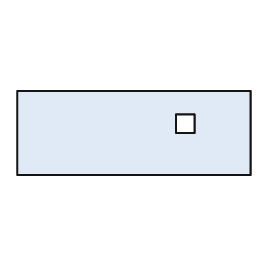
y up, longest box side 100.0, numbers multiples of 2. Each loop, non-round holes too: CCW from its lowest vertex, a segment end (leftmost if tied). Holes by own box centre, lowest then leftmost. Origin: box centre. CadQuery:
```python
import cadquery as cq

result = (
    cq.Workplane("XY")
    .moveTo(-50.0, -18.0)
    .lineTo(50.0, -18.0)
    .lineTo(50.0, 18.0)
    .lineTo(-50.0, 18.0)
    .close()
    .moveTo(18.0, 0.0)
    .lineTo(26.0, 0.0)
    .lineTo(26.0, 8.0)
    .lineTo(18.0, 8.0)
    .close()
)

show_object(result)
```